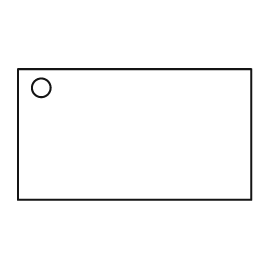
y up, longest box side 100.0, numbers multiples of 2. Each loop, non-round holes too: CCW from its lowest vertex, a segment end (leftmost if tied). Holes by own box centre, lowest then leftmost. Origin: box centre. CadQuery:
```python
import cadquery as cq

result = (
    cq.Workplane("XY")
    .moveTo(-50.0, -28.0)
    .lineTo(50.0, -28.0)
    .lineTo(50.0, 28.0)
    .lineTo(-50.0, 28.0)
    .close()
    .moveTo(-40.0, 20.0)
    .circle(4.0)
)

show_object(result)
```